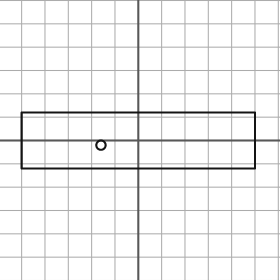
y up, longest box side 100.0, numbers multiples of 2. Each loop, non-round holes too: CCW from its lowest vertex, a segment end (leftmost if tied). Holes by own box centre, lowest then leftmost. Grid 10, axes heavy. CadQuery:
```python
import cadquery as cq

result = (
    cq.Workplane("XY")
    .moveTo(-50.0, -12.0)
    .lineTo(50.0, -12.0)
    .lineTo(50.0, 12.0)
    .lineTo(-50.0, 12.0)
    .close()
    .moveTo(-16.0, -2.0)
    .circle(2.0)
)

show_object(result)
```